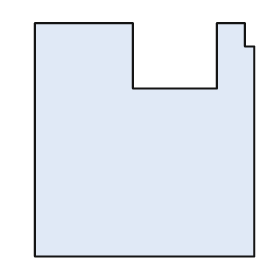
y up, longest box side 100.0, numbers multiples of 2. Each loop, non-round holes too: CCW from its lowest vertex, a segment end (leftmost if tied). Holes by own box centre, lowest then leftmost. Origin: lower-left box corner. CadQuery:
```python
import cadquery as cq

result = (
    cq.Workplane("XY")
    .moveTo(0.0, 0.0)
    .lineTo(94.0, 0.0)
    .lineTo(94.0, 90.0)
    .lineTo(90.0, 90.0)
    .lineTo(90.0, 100.0)
    .lineTo(78.0, 100.0)
    .lineTo(78.0, 72.0)
    .lineTo(42.0, 72.0)
    .lineTo(42.0, 100.0)
    .lineTo(0.0, 100.0)
    .close()
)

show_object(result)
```